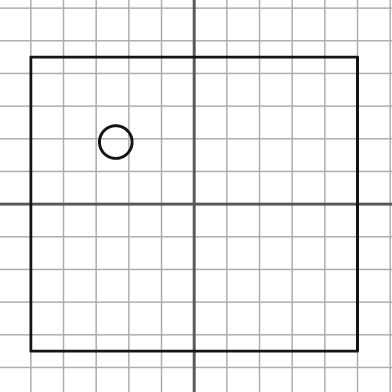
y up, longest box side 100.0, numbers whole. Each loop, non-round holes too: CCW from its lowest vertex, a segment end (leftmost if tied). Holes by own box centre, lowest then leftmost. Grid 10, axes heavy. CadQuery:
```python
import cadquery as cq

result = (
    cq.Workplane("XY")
    .moveTo(-50.0, -45.0)
    .lineTo(50.0, -45.0)
    .lineTo(50.0, 45.0)
    .lineTo(-50.0, 45.0)
    .close()
    .moveTo(-24.0, 19.0)
    .circle(5.0)
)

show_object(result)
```